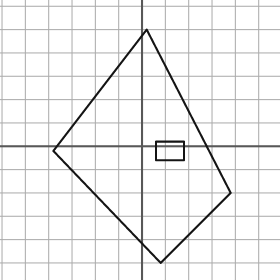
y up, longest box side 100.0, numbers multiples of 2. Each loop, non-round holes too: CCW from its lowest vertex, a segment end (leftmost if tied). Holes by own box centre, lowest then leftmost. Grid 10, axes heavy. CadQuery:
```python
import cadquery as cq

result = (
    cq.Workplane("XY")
    .moveTo(8.0, -50.0)
    .lineTo(38.0, -20.0)
    .lineTo(2.0, 50.0)
    .lineTo(-38.0, -2.0)
    .close()
    .moveTo(6.0, -6.0)
    .lineTo(18.0, -6.0)
    .lineTo(18.0, 2.0)
    .lineTo(6.0, 2.0)
    .close()
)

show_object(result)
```